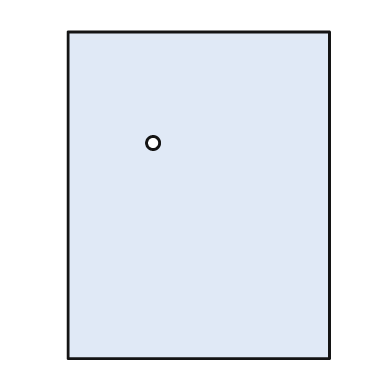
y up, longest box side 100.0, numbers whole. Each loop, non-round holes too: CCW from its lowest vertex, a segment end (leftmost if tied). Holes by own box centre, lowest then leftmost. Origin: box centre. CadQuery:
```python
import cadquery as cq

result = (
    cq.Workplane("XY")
    .moveTo(-40.0, -50.0)
    .lineTo(40.0, -50.0)
    .lineTo(40.0, 50.0)
    .lineTo(-40.0, 50.0)
    .close()
    .moveTo(-14.0, 16.0)
    .circle(2.0)
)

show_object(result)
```